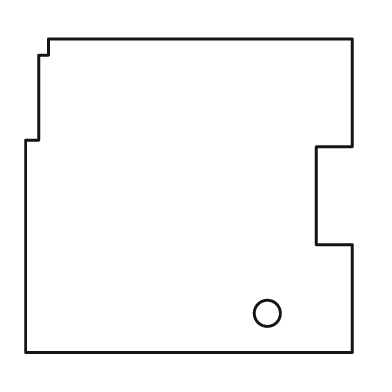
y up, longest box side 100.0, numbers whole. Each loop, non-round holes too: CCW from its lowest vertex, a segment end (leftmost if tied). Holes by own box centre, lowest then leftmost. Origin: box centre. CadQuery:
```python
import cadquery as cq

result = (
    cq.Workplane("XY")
    .moveTo(-50.0, -48.0)
    .lineTo(50.0, -48.0)
    .lineTo(50.0, -15.0)
    .lineTo(39.0, -15.0)
    .lineTo(39.0, 15.0)
    .lineTo(50.0, 15.0)
    .lineTo(50.0, 48.0)
    .lineTo(-43.0, 48.0)
    .lineTo(-43.0, 43.0)
    .lineTo(-46.0, 43.0)
    .lineTo(-46.0, 17.0)
    .lineTo(-50.0, 17.0)
    .close()
    .moveTo(24.0, -36.0)
    .circle(4.0)
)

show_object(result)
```